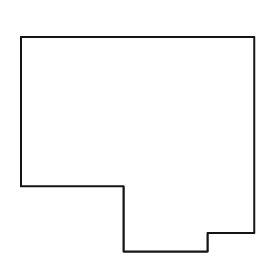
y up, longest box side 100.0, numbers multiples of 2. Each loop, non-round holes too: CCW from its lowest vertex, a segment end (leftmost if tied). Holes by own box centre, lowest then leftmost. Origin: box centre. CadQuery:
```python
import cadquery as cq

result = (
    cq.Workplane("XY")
    .moveTo(-6.0, -46.0)
    .lineTo(30.0, -46.0)
    .lineTo(30.0, -38.0)
    .lineTo(50.0, -38.0)
    .lineTo(50.0, 46.0)
    .lineTo(-50.0, 46.0)
    .lineTo(-50.0, -18.0)
    .lineTo(-6.0, -18.0)
    .close()
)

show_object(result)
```